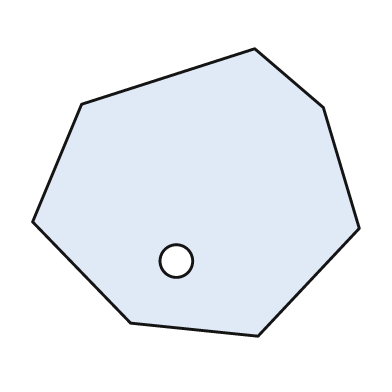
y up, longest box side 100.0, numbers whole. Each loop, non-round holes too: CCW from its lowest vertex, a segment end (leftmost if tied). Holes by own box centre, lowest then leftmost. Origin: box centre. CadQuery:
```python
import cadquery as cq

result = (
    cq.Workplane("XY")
    .moveTo(19.0, -44.0)
    .lineTo(50.0, -11.0)
    .lineTo(39.0, 26.0)
    .lineTo(18.0, 44.0)
    .lineTo(-35.0, 27.0)
    .lineTo(-50.0, -9.0)
    .lineTo(-20.0, -40.0)
    .close()
    .moveTo(-6.0, -21.0)
    .circle(5.0)
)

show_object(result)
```